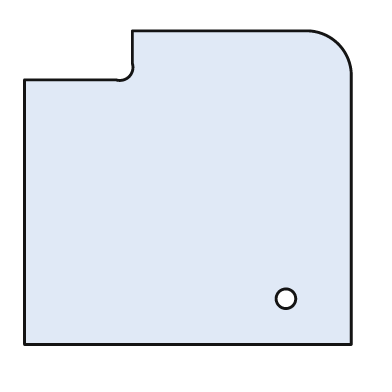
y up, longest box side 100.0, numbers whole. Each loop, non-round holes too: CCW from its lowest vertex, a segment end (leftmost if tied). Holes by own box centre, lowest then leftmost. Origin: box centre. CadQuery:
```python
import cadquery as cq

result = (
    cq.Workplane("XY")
    .moveTo(-50.0, -48.0)
    .lineTo(50.0, -48.0)
    .lineTo(50.0, 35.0)
    .threePointArc((46.0, 44.0), (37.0, 48.0))
    .lineTo(-17.0, 48.0)
    .lineTo(-17.0, 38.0)
    .threePointArc((-18.0, 34.0), (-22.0, 33.0))
    .lineTo(-50.0, 33.0)
    .close()
    .moveTo(30.0, -34.0)
    .circle(3.0)
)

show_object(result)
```